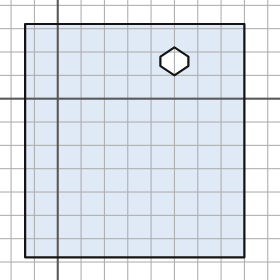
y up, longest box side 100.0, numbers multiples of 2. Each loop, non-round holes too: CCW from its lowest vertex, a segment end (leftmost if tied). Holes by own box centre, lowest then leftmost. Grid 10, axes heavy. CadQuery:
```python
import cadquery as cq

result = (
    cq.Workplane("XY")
    .moveTo(-14.0, -68.0)
    .lineTo(80.0, -68.0)
    .lineTo(80.0, 32.0)
    .lineTo(-14.0, 32.0)
    .close()
    .moveTo(50.0, 10.0)
    .lineTo(56.0, 14.0)
    .lineTo(56.0, 18.0)
    .lineTo(50.0, 22.0)
    .lineTo(44.0, 18.0)
    .lineTo(44.0, 14.0)
    .close()
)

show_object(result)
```